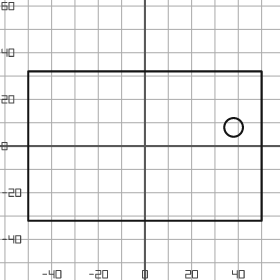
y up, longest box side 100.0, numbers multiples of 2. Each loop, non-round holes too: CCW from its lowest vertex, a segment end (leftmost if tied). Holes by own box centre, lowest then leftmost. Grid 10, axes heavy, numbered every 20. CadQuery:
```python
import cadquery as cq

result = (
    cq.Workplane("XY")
    .moveTo(-50.0, -32.0)
    .lineTo(50.0, -32.0)
    .lineTo(50.0, 32.0)
    .lineTo(-50.0, 32.0)
    .close()
    .moveTo(38.0, 8.0)
    .circle(4.0)
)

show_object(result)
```